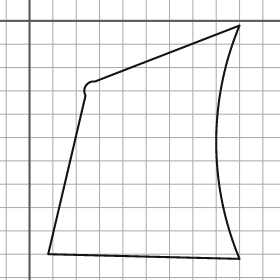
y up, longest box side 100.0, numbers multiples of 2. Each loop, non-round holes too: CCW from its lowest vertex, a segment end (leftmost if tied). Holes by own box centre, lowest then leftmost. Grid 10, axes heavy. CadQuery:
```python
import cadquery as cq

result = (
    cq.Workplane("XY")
    .moveTo(90.0, -102.0)
    .threePointArc((80.0, -52.0), (90.0, -2.0))
    .lineTo(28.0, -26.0)
    .threePointArc((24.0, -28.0), (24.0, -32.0))
    .lineTo(8.0, -100.0)
    .close()
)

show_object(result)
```